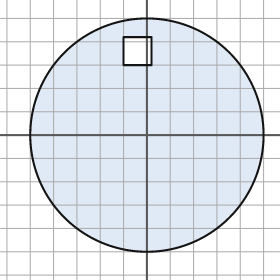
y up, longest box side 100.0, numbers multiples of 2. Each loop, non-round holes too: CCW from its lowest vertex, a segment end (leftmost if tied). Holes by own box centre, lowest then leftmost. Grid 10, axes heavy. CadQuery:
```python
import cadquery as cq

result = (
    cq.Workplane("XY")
    .moveTo(0.0, 0.0)
    .circle(50.0)
    .moveTo(-10.0, 30.0)
    .lineTo(2.0, 30.0)
    .lineTo(2.0, 42.0)
    .lineTo(-10.0, 42.0)
    .close()
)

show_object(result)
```